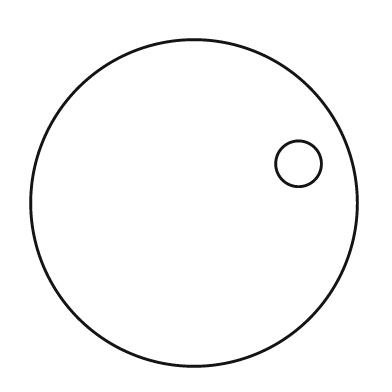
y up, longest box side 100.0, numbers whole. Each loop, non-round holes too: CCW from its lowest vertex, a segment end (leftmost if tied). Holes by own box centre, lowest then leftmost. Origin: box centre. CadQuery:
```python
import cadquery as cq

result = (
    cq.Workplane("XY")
    .moveTo(0.0, 0.0)
    .circle(50.0)
    .moveTo(32.0, 12.0)
    .circle(7.0)
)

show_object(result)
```